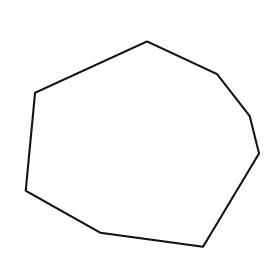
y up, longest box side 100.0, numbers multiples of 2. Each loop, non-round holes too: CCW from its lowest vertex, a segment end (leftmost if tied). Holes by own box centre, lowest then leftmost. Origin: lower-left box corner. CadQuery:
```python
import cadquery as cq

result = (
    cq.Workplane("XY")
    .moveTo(76.0, 0.0)
    .lineTo(100.0, 40.0)
    .lineTo(96.0, 56.0)
    .lineTo(82.0, 74.0)
    .lineTo(52.0, 88.0)
    .lineTo(4.0, 66.0)
    .lineTo(0.0, 24.0)
    .lineTo(32.0, 6.0)
    .close()
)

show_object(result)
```